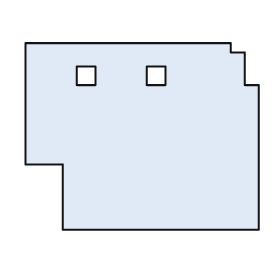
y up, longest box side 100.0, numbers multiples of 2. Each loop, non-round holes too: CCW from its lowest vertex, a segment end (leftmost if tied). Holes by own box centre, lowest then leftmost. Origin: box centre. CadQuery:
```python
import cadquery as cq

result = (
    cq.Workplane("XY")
    .moveTo(-34.0, -40.0)
    .lineTo(50.0, -40.0)
    .lineTo(50.0, 22.0)
    .lineTo(44.0, 22.0)
    .lineTo(44.0, 36.0)
    .lineTo(38.0, 36.0)
    .lineTo(38.0, 40.0)
    .lineTo(-50.0, 40.0)
    .lineTo(-50.0, -12.0)
    .lineTo(-34.0, -12.0)
    .close()
    .moveTo(-28.0, 22.0)
    .lineTo(-20.0, 22.0)
    .lineTo(-20.0, 30.0)
    .lineTo(-28.0, 30.0)
    .close()
    .moveTo(2.0, 22.0)
    .lineTo(10.0, 22.0)
    .lineTo(10.0, 30.0)
    .lineTo(2.0, 30.0)
    .close()
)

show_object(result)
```